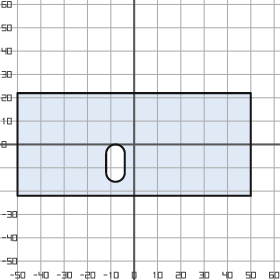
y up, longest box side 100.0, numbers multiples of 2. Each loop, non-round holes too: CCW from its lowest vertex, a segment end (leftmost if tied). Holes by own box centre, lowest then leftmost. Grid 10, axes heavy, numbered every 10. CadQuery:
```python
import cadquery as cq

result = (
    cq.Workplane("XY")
    .moveTo(-50.0, -22.0)
    .lineTo(50.0, -22.0)
    .lineTo(50.0, 22.0)
    .lineTo(-50.0, 22.0)
    .close()
    .moveTo(-12.0, -12.0)
    .threePointArc((-8.0, -16.0), (-4.0, -12.0))
    .lineTo(-4.0, -4.0)
    .threePointArc((-8.0, 0.0), (-12.0, -4.0))
    .close()
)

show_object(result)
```